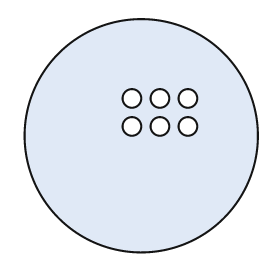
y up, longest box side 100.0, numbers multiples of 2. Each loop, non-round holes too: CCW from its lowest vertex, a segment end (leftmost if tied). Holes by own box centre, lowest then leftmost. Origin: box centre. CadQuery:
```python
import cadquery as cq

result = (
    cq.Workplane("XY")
    .moveTo(0.0, 0.0)
    .circle(50.0)
    .moveTo(-4.0, 4.0)
    .circle(4.0)
    .moveTo(8.0, 4.0)
    .circle(4.0)
    .moveTo(20.0, 4.0)
    .circle(4.0)
    .moveTo(-4.0, 16.0)
    .circle(4.0)
    .moveTo(8.0, 16.0)
    .circle(4.0)
    .moveTo(20.0, 16.0)
    .circle(4.0)
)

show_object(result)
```